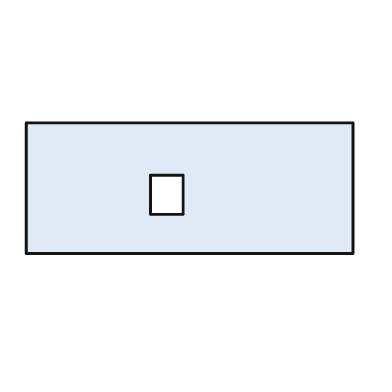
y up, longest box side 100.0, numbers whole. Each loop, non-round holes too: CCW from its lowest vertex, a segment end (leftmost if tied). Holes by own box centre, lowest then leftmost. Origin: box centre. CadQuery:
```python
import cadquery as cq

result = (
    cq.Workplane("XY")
    .moveTo(-50.0, -20.0)
    .lineTo(50.0, -20.0)
    .lineTo(50.0, 20.0)
    .lineTo(-50.0, 20.0)
    .close()
    .moveTo(-12.0, -8.0)
    .lineTo(-2.0, -8.0)
    .lineTo(-2.0, 4.0)
    .lineTo(-12.0, 4.0)
    .close()
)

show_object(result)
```